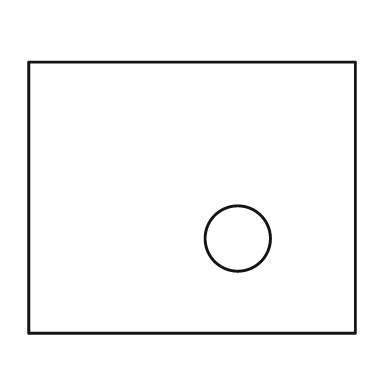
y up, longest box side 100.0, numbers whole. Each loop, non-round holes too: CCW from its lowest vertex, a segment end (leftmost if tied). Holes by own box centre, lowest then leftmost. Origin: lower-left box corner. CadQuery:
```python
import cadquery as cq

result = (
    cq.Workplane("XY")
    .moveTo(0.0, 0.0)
    .lineTo(100.0, 0.0)
    .lineTo(100.0, 83.0)
    .lineTo(0.0, 83.0)
    .close()
    .moveTo(64.0, 29.0)
    .circle(10.0)
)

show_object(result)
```